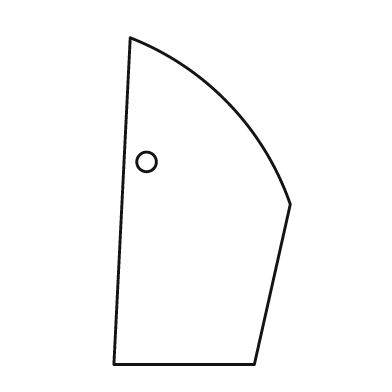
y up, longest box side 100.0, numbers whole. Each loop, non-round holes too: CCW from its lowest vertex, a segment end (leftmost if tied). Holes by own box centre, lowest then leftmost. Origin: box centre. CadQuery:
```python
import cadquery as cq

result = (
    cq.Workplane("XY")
    .moveTo(-27.0, -50.0)
    .lineTo(16.0, -50.0)
    .lineTo(27.0, -1.0)
    .threePointArc((8.0, 30.0), (-22.0, 50.0))
    .close()
    .moveTo(-17.0, 12.0)
    .circle(3.0)
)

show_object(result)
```